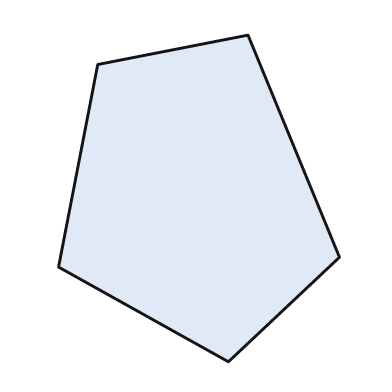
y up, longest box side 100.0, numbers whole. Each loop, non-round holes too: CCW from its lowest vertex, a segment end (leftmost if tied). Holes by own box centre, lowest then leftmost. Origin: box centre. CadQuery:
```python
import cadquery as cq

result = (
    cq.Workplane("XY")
    .moveTo(9.0, -50.0)
    .lineTo(43.0, -18.0)
    .lineTo(15.0, 50.0)
    .lineTo(-31.0, 41.0)
    .lineTo(-43.0, -21.0)
    .close()
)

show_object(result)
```